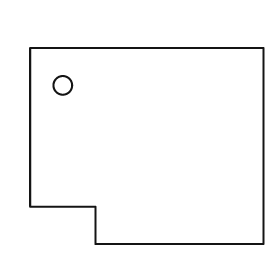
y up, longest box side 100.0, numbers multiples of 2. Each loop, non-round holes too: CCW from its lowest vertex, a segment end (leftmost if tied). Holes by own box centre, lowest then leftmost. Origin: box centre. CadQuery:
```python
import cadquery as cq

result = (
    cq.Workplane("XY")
    .moveTo(-22.0, -42.0)
    .lineTo(50.0, -42.0)
    .lineTo(50.0, 42.0)
    .lineTo(-50.0, 42.0)
    .lineTo(-50.0, -26.0)
    .lineTo(-22.0, -26.0)
    .close()
    .moveTo(-36.0, 26.0)
    .circle(4.0)
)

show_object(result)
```